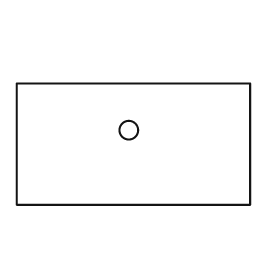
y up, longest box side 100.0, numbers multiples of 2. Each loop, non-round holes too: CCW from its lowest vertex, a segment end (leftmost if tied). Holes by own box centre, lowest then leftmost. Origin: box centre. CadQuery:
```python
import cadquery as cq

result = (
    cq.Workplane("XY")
    .moveTo(-50.0, -26.0)
    .lineTo(50.0, -26.0)
    .lineTo(50.0, 26.0)
    .lineTo(-50.0, 26.0)
    .close()
    .moveTo(-2.0, 6.0)
    .circle(4.0)
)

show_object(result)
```